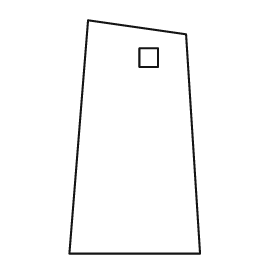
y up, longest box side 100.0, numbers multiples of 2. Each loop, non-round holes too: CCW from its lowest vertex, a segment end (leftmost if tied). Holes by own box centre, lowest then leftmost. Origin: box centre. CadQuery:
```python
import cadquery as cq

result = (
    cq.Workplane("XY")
    .moveTo(-28.0, -50.0)
    .lineTo(28.0, -50.0)
    .lineTo(22.0, 44.0)
    .lineTo(-20.0, 50.0)
    .close()
    .moveTo(2.0, 30.0)
    .lineTo(10.0, 30.0)
    .lineTo(10.0, 38.0)
    .lineTo(2.0, 38.0)
    .close()
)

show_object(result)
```